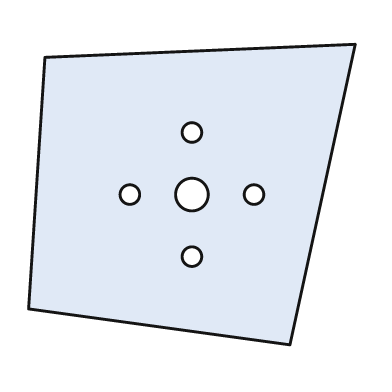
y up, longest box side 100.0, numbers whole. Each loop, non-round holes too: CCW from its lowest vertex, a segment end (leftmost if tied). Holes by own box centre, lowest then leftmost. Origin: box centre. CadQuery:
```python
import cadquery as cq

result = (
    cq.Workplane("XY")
    .moveTo(30.0, -46.0)
    .lineTo(50.0, 46.0)
    .lineTo(-45.0, 42.0)
    .lineTo(-50.0, -35.0)
    .close()
    .moveTo(0.0, -19.0)
    .circle(3.0)
    .moveTo(-19.0, 0.0)
    .circle(3.0)
    .moveTo(0.0, 0.0)
    .circle(5.0)
    .moveTo(19.0, 0.0)
    .circle(3.0)
    .moveTo(0.0, 19.0)
    .circle(3.0)
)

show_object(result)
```